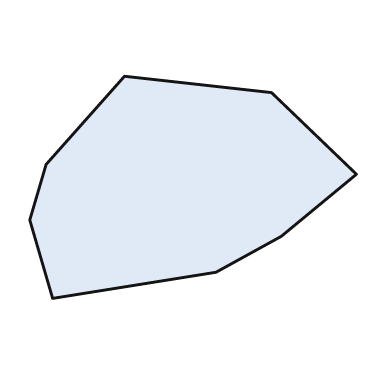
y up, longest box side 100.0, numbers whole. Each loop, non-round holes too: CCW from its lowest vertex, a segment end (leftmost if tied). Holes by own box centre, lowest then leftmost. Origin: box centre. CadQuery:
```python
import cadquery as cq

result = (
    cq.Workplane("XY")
    .moveTo(-43.0, -34.0)
    .lineTo(7.0, -26.0)
    .lineTo(27.0, -15.0)
    .lineTo(50.0, 4.0)
    .lineTo(24.0, 29.0)
    .lineTo(-21.0, 34.0)
    .lineTo(-45.0, 7.0)
    .lineTo(-50.0, -10.0)
    .close()
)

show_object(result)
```